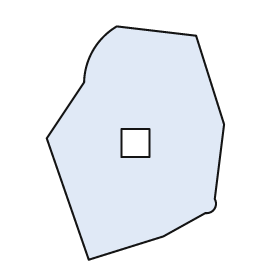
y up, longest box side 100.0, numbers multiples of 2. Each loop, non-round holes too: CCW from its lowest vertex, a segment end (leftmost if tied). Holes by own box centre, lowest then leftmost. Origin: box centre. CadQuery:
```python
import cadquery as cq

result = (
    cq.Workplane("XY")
    .moveTo(-20.0, -50.0)
    .lineTo(12.0, -40.0)
    .lineTo(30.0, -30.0)
    .threePointArc((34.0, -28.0), (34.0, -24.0))
    .lineTo(38.0, 8.0)
    .lineTo(26.0, 46.0)
    .lineTo(-8.0, 50.0)
    .threePointArc((-18.0, 40.0), (-22.0, 26.0))
    .lineTo(-38.0, 2.0)
    .close()
    .moveTo(-6.0, -6.0)
    .lineTo(6.0, -6.0)
    .lineTo(6.0, 6.0)
    .lineTo(-6.0, 6.0)
    .close()
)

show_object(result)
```